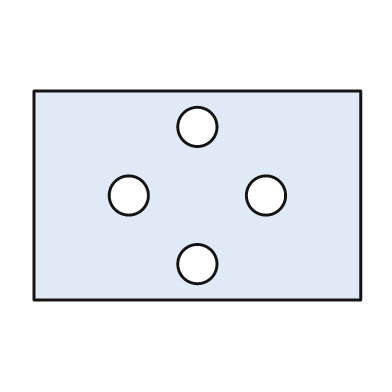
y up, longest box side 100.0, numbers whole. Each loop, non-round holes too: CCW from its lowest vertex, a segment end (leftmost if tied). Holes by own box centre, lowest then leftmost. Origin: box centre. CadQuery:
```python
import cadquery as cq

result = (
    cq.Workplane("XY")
    .moveTo(-50.0, -32.0)
    .lineTo(50.0, -32.0)
    .lineTo(50.0, 32.0)
    .lineTo(-50.0, 32.0)
    .close()
    .moveTo(0.0, -21.0)
    .circle(6.0)
    .moveTo(-21.0, 0.0)
    .circle(6.0)
    .moveTo(21.0, 0.0)
    .circle(6.0)
    .moveTo(0.0, 21.0)
    .circle(6.0)
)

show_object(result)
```